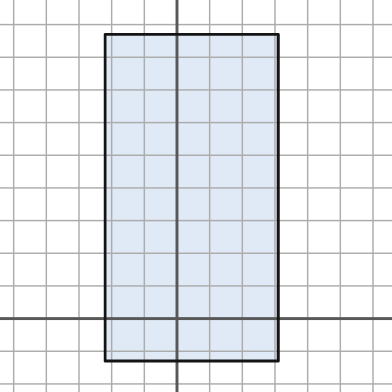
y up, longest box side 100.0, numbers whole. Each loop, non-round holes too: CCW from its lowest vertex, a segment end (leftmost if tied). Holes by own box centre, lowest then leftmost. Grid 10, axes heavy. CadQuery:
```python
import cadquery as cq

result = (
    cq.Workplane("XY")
    .moveTo(-22.0, -13.0)
    .lineTo(31.0, -13.0)
    .lineTo(31.0, 87.0)
    .lineTo(-22.0, 87.0)
    .close()
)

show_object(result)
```